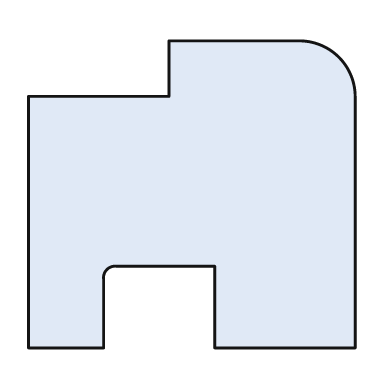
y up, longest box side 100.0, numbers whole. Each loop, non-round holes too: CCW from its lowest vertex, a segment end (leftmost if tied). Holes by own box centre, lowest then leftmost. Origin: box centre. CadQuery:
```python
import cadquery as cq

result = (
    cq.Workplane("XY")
    .moveTo(-50.0, -47.0)
    .lineTo(-27.0, -47.0)
    .lineTo(-27.0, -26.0)
    .threePointArc((-26.0, -23.0), (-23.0, -22.0))
    .lineTo(7.0, -22.0)
    .lineTo(7.0, -47.0)
    .lineTo(50.0, -47.0)
    .lineTo(50.0, 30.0)
    .threePointArc((45.0, 42.0), (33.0, 47.0))
    .lineTo(-7.0, 47.0)
    .lineTo(-7.0, 30.0)
    .lineTo(-50.0, 30.0)
    .close()
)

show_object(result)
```